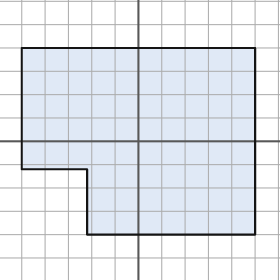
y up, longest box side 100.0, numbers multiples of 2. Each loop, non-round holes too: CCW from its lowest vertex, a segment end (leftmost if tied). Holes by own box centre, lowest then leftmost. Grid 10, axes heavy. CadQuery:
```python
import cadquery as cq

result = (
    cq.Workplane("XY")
    .moveTo(-22.0, -40.0)
    .lineTo(50.0, -40.0)
    .lineTo(50.0, 40.0)
    .lineTo(-50.0, 40.0)
    .lineTo(-50.0, -12.0)
    .lineTo(-22.0, -12.0)
    .close()
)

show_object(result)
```